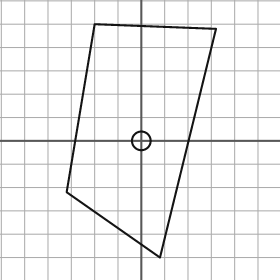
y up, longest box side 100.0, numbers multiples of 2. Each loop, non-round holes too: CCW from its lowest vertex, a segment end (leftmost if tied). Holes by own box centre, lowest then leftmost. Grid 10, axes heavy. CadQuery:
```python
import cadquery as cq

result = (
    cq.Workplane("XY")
    .moveTo(8.0, -50.0)
    .lineTo(32.0, 48.0)
    .lineTo(-20.0, 50.0)
    .lineTo(-32.0, -22.0)
    .close()
    .moveTo(0.0, 0.0)
    .circle(4.0)
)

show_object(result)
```